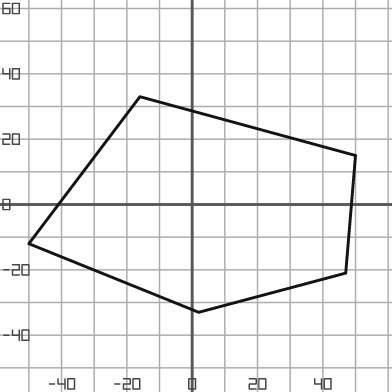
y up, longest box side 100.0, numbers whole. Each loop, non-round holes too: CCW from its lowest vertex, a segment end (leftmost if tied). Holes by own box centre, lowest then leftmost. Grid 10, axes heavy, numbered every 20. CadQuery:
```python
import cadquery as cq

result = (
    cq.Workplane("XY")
    .moveTo(2.0, -33.0)
    .lineTo(47.0, -21.0)
    .lineTo(50.0, 15.0)
    .lineTo(-16.0, 33.0)
    .lineTo(-50.0, -12.0)
    .close()
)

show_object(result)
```